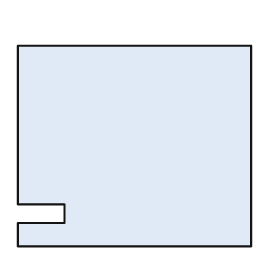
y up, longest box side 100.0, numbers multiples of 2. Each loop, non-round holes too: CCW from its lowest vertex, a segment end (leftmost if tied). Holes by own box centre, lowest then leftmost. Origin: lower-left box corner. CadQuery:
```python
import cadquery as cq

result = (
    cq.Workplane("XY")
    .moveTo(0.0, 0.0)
    .lineTo(100.0, 0.0)
    .lineTo(100.0, 86.0)
    .lineTo(0.0, 86.0)
    .lineTo(0.0, 18.0)
    .lineTo(20.0, 18.0)
    .lineTo(20.0, 10.0)
    .lineTo(0.0, 10.0)
    .close()
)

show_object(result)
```